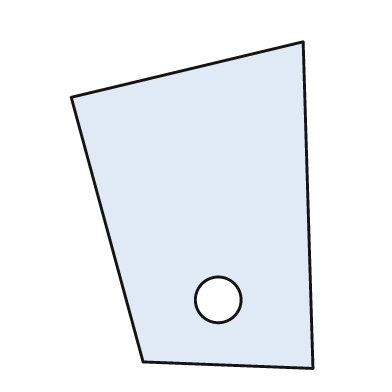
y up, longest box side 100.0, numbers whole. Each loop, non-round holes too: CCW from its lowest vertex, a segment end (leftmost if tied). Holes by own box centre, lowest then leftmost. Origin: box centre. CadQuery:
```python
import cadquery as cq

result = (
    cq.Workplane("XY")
    .moveTo(37.0, -50.0)
    .lineTo(34.0, 50.0)
    .lineTo(-37.0, 33.0)
    .lineTo(-15.0, -48.0)
    .close()
    .moveTo(8.0, -29.0)
    .circle(7.0)
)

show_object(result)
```